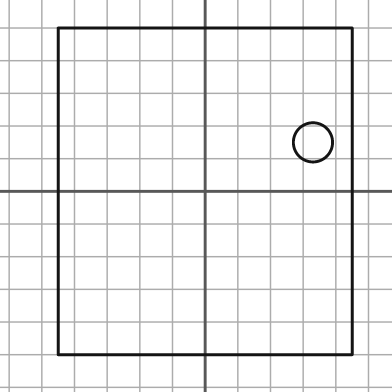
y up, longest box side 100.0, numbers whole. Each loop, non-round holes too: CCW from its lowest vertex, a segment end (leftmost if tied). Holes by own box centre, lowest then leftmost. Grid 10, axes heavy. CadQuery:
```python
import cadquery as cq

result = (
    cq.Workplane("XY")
    .moveTo(-45.0, -50.0)
    .lineTo(45.0, -50.0)
    .lineTo(45.0, 50.0)
    .lineTo(-45.0, 50.0)
    .close()
    .moveTo(33.0, 15.0)
    .circle(6.0)
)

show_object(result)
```